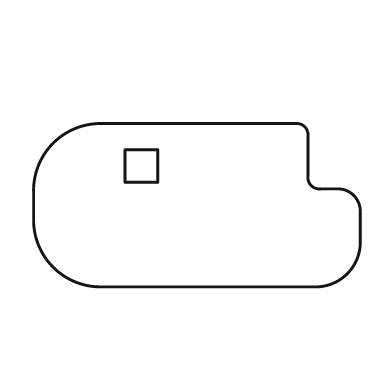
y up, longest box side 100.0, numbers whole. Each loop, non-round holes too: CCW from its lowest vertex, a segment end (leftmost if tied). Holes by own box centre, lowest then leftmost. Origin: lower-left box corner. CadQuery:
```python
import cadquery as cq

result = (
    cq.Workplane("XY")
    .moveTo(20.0, 0.0)
    .lineTo(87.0, 0.0)
    .threePointArc((96.0, 4.0), (100.0, 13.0))
    .lineTo(100.0, 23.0)
    .threePointArc((98.0, 28.0), (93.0, 30.0))
    .lineTo(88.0, 30.0)
    .threePointArc((85.0, 31.0), (84.0, 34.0))
    .lineTo(84.0, 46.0)
    .threePointArc((83.0, 49.0), (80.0, 50.0))
    .lineTo(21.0, 50.0)
    .threePointArc((6.0, 44.0), (0.0, 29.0))
    .lineTo(0.0, 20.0)
    .threePointArc((6.0, 6.0), (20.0, 0.0))
    .close()
    .moveTo(28.0, 32.0)
    .lineTo(38.0, 32.0)
    .lineTo(38.0, 42.0)
    .lineTo(28.0, 42.0)
    .close()
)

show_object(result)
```